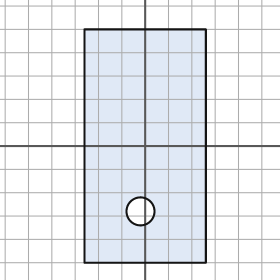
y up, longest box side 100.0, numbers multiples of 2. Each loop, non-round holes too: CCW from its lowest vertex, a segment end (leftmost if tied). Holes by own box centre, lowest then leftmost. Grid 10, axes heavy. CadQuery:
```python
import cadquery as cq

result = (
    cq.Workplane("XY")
    .moveTo(-26.0, -50.0)
    .lineTo(26.0, -50.0)
    .lineTo(26.0, 50.0)
    .lineTo(-26.0, 50.0)
    .close()
    .moveTo(-2.0, -28.0)
    .circle(6.0)
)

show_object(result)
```